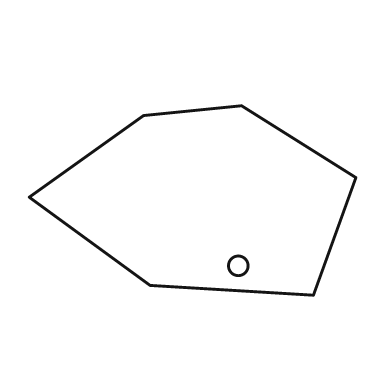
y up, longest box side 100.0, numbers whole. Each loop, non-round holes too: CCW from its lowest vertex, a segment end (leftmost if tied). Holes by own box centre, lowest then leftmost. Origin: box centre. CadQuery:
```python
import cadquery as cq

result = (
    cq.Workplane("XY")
    .moveTo(37.0, -29.0)
    .lineTo(50.0, 7.0)
    .lineTo(15.0, 29.0)
    .lineTo(-15.0, 26.0)
    .lineTo(-50.0, 1.0)
    .lineTo(-13.0, -26.0)
    .close()
    .moveTo(14.0, -20.0)
    .circle(3.0)
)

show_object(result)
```